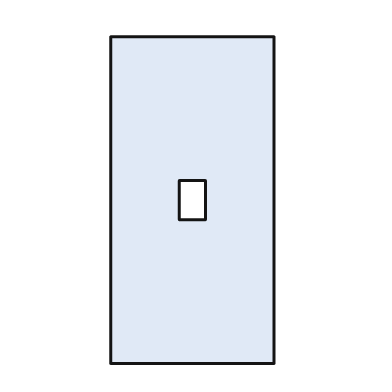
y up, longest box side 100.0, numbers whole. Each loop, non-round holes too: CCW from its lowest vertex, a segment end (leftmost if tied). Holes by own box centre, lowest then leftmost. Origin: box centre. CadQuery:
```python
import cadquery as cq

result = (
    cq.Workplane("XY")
    .moveTo(-25.0, -50.0)
    .lineTo(25.0, -50.0)
    .lineTo(25.0, 50.0)
    .lineTo(-25.0, 50.0)
    .close()
    .moveTo(-4.0, -6.0)
    .lineTo(4.0, -6.0)
    .lineTo(4.0, 6.0)
    .lineTo(-4.0, 6.0)
    .close()
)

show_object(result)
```